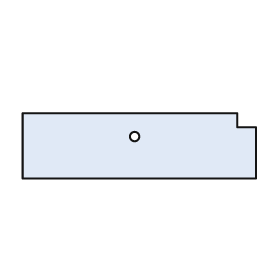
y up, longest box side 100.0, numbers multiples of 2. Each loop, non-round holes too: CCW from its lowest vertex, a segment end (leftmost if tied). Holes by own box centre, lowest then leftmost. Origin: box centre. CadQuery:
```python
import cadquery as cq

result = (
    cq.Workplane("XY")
    .moveTo(-50.0, -14.0)
    .lineTo(50.0, -14.0)
    .lineTo(50.0, 8.0)
    .lineTo(42.0, 8.0)
    .lineTo(42.0, 14.0)
    .lineTo(-50.0, 14.0)
    .close()
    .moveTo(-2.0, 4.0)
    .circle(2.0)
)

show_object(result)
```